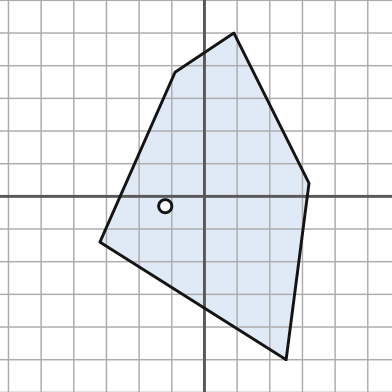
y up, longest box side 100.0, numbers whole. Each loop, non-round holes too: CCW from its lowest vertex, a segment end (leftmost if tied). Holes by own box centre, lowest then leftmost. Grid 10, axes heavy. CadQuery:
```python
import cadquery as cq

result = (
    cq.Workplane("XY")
    .moveTo(25.0, -50.0)
    .lineTo(32.0, 4.0)
    .lineTo(9.0, 50.0)
    .lineTo(-9.0, 38.0)
    .lineTo(-32.0, -14.0)
    .close()
    .moveTo(-12.0, -3.0)
    .circle(2.0)
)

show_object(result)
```